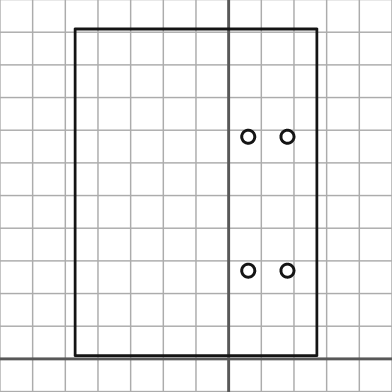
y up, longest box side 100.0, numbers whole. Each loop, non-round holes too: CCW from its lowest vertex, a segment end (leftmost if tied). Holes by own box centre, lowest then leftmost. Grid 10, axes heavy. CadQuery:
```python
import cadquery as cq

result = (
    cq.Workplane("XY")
    .moveTo(-47.0, 1.0)
    .lineTo(27.0, 1.0)
    .lineTo(27.0, 101.0)
    .lineTo(-47.0, 101.0)
    .close()
    .moveTo(6.0, 27.0)
    .circle(2.0)
    .moveTo(18.0, 27.0)
    .circle(2.0)
    .moveTo(6.0, 68.0)
    .circle(2.0)
    .moveTo(18.0, 68.0)
    .circle(2.0)
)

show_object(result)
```